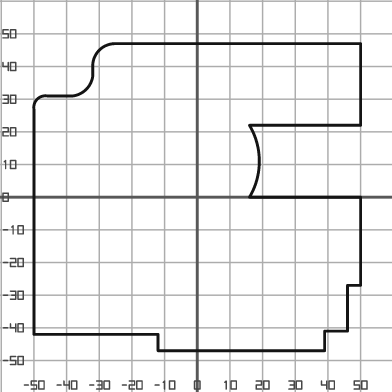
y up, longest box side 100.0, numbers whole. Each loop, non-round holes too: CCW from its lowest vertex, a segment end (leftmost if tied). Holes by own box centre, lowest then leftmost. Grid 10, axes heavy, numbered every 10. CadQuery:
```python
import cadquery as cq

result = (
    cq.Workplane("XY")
    .moveTo(-12.0, -47.0)
    .lineTo(39.0, -47.0)
    .lineTo(39.0, -41.0)
    .lineTo(46.0, -41.0)
    .lineTo(46.0, -27.0)
    .lineTo(50.0, -27.0)
    .lineTo(50.0, 0.0)
    .lineTo(16.0, 0.0)
    .threePointArc((19.0, 11.0), (16.0, 22.0))
    .lineTo(50.0, 22.0)
    .lineTo(50.0, 47.0)
    .lineTo(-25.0, 47.0)
    .threePointArc((-30.0, 45.0), (-32.0, 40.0))
    .lineTo(-32.0, 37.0)
    .threePointArc((-34.0, 33.0), (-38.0, 31.0))
    .lineTo(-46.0, 31.0)
    .threePointArc((-49.0, 30.0), (-50.0, 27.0))
    .lineTo(-50.0, -42.0)
    .lineTo(-12.0, -42.0)
    .close()
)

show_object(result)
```